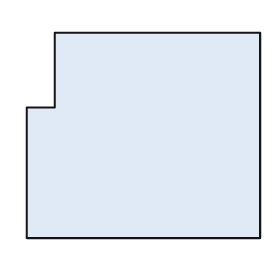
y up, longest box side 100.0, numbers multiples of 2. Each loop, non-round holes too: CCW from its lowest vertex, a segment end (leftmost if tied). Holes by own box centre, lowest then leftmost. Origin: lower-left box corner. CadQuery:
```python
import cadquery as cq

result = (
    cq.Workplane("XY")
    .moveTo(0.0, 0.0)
    .lineTo(100.0, 0.0)
    .lineTo(100.0, 88.0)
    .lineTo(12.0, 88.0)
    .lineTo(12.0, 56.0)
    .lineTo(0.0, 56.0)
    .close()
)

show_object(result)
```